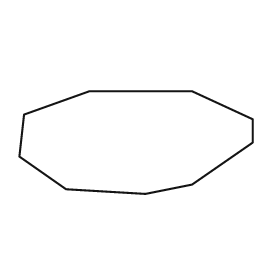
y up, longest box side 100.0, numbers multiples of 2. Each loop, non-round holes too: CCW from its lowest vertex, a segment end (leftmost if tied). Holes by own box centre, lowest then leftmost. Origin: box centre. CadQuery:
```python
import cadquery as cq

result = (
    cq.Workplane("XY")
    .moveTo(4.0, -22.0)
    .lineTo(24.0, -18.0)
    .lineTo(50.0, 0.0)
    .lineTo(50.0, 10.0)
    .lineTo(24.0, 22.0)
    .lineTo(-20.0, 22.0)
    .lineTo(-48.0, 12.0)
    .lineTo(-50.0, -6.0)
    .lineTo(-30.0, -20.0)
    .close()
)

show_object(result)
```